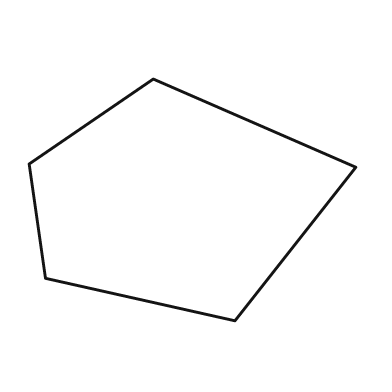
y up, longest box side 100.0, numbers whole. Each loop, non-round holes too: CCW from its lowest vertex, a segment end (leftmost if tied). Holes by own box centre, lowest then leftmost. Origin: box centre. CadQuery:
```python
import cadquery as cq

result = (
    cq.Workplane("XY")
    .moveTo(13.0, -37.0)
    .lineTo(50.0, 10.0)
    .lineTo(-12.0, 37.0)
    .lineTo(-50.0, 11.0)
    .lineTo(-45.0, -24.0)
    .close()
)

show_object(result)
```